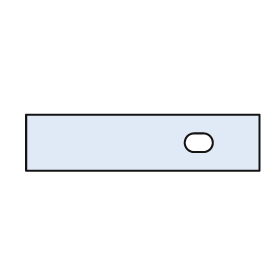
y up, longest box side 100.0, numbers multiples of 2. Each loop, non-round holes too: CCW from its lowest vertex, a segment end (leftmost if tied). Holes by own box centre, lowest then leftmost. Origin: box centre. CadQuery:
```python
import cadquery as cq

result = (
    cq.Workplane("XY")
    .moveTo(-50.0, -12.0)
    .lineTo(50.0, -12.0)
    .lineTo(50.0, 12.0)
    .lineTo(-50.0, 12.0)
    .close()
    .moveTo(22.0, -4.0)
    .lineTo(26.0, -4.0)
    .threePointArc((30.0, 0.0), (26.0, 4.0))
    .lineTo(22.0, 4.0)
    .threePointArc((18.0, 0.0), (22.0, -4.0))
    .close()
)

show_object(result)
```